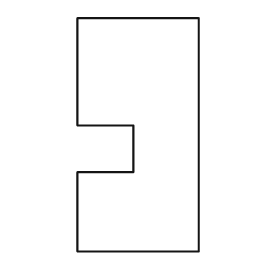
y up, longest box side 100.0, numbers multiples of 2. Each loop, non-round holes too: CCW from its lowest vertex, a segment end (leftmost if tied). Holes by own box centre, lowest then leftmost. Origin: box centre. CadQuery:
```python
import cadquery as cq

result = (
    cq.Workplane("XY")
    .moveTo(-26.0, -50.0)
    .lineTo(26.0, -50.0)
    .lineTo(26.0, 50.0)
    .lineTo(-26.0, 50.0)
    .lineTo(-26.0, 4.0)
    .lineTo(-2.0, 4.0)
    .lineTo(-2.0, -16.0)
    .lineTo(-26.0, -16.0)
    .close()
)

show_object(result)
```